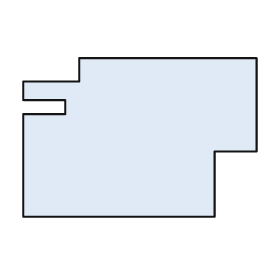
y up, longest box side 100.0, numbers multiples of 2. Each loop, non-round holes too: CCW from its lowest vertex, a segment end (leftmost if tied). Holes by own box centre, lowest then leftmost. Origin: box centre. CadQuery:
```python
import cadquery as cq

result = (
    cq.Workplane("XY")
    .moveTo(-50.0, -34.0)
    .lineTo(32.0, -34.0)
    .lineTo(32.0, -6.0)
    .lineTo(50.0, -6.0)
    .lineTo(50.0, 34.0)
    .lineTo(-26.0, 34.0)
    .lineTo(-26.0, 24.0)
    .lineTo(-50.0, 24.0)
    .lineTo(-50.0, 16.0)
    .lineTo(-32.0, 16.0)
    .lineTo(-32.0, 10.0)
    .lineTo(-50.0, 10.0)
    .close()
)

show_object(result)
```